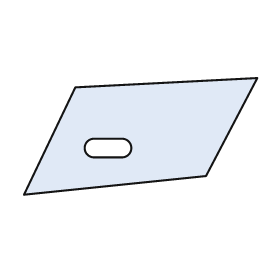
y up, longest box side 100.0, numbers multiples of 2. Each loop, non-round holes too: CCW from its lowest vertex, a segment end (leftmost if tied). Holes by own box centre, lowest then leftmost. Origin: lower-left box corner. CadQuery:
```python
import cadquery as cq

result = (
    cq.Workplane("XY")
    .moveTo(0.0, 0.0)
    .lineTo(78.0, 8.0)
    .lineTo(100.0, 50.0)
    .lineTo(22.0, 46.0)
    .close()
    .moveTo(30.0, 16.0)
    .lineTo(42.0, 16.0)
    .threePointArc((46.0, 20.0), (42.0, 24.0))
    .lineTo(30.0, 24.0)
    .threePointArc((26.0, 20.0), (30.0, 16.0))
    .close()
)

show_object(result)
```